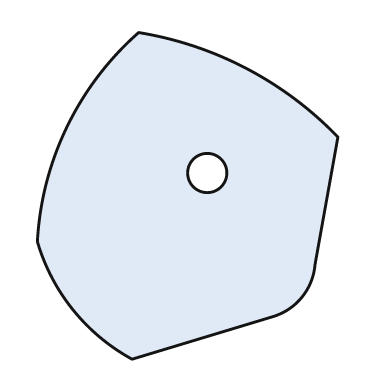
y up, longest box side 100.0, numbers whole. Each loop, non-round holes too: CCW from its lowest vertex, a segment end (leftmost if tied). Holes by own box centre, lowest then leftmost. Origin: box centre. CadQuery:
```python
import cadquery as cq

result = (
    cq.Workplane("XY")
    .moveTo(-17.0, -50.0)
    .lineTo(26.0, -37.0)
    .threePointArc((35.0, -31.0), (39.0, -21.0))
    .lineTo(46.0, 18.0)
    .threePointArc((18.0, 39.0), (-15.0, 50.0))
    .threePointArc((-37.0, 21.0), (-46.0, -14.0))
    .threePointArc((-35.0, -35.0), (-17.0, -50.0))
    .close()
    .moveTo(6.0, 7.0)
    .circle(6.0)
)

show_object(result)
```